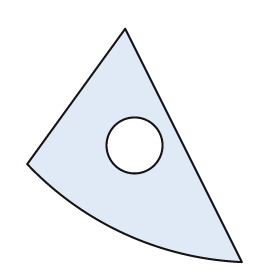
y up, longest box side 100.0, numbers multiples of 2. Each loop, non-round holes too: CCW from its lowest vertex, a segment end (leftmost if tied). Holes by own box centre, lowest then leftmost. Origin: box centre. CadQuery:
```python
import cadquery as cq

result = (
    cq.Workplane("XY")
    .moveTo(46.0, -50.0)
    .lineTo(-4.0, 50.0)
    .lineTo(-46.0, -8.0)
    .threePointArc((-4.0, -38.0), (46.0, -50.0))
    .close()
    .moveTo(0.0, 0.0)
    .circle(12.0)
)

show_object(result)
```